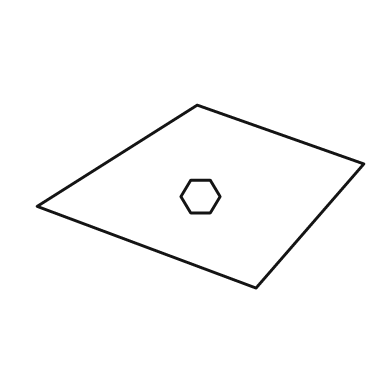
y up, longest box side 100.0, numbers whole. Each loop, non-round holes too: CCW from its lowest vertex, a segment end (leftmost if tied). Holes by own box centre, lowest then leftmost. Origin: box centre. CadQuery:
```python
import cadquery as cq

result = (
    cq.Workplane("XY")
    .moveTo(17.0, -28.0)
    .lineTo(50.0, 10.0)
    .lineTo(-1.0, 28.0)
    .lineTo(-50.0, -3.0)
    .close()
    .moveTo(-3.0, -5.0)
    .lineTo(3.0, -5.0)
    .lineTo(6.0, 0.0)
    .lineTo(3.0, 5.0)
    .lineTo(-3.0, 5.0)
    .lineTo(-6.0, 0.0)
    .close()
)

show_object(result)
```